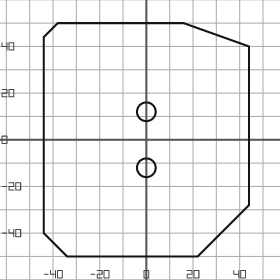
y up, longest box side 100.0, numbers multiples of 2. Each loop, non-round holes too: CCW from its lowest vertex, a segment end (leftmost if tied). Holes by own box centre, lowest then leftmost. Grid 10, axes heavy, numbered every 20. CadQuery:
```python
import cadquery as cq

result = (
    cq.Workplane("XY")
    .moveTo(-34.0, -50.0)
    .lineTo(22.0, -50.0)
    .lineTo(44.0, -28.0)
    .lineTo(44.0, 40.0)
    .lineTo(16.0, 50.0)
    .lineTo(-38.0, 50.0)
    .lineTo(-44.0, 44.0)
    .lineTo(-44.0, -40.0)
    .close()
    .moveTo(0.0, -12.0)
    .circle(4.0)
    .moveTo(0.0, 12.0)
    .circle(4.0)
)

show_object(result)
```